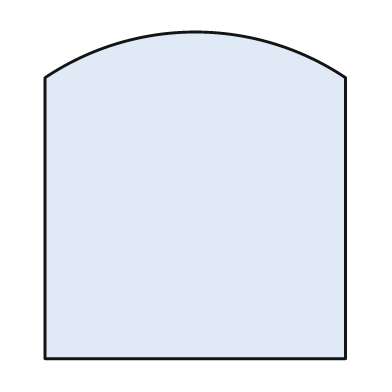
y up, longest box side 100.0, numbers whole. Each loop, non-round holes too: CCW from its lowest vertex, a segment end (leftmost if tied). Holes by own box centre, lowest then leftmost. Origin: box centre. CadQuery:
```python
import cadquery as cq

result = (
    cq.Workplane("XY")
    .moveTo(-46.0, -50.0)
    .lineTo(46.0, -50.0)
    .lineTo(46.0, 36.0)
    .threePointArc((0.0, 50.0), (-46.0, 36.0))
    .close()
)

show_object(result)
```